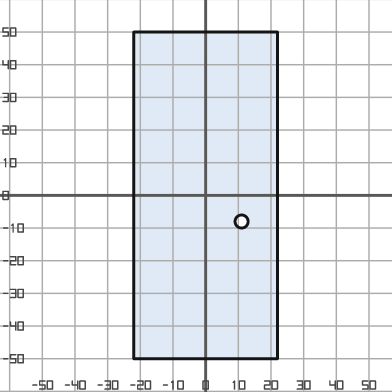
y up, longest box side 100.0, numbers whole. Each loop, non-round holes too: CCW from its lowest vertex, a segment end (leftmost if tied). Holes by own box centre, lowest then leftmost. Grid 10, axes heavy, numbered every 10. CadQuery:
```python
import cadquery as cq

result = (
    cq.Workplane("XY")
    .moveTo(-22.0, -50.0)
    .lineTo(22.0, -50.0)
    .lineTo(22.0, 50.0)
    .lineTo(-22.0, 50.0)
    .close()
    .moveTo(11.0, -8.0)
    .circle(2.0)
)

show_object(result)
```